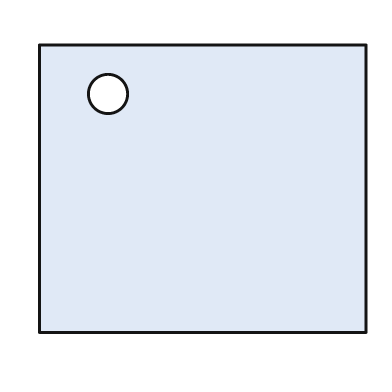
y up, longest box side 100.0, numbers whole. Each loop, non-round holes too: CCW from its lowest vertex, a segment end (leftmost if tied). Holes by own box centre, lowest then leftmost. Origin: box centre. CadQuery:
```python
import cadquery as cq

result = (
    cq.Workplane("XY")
    .moveTo(-50.0, -44.0)
    .lineTo(50.0, -44.0)
    .lineTo(50.0, 44.0)
    .lineTo(-50.0, 44.0)
    .close()
    .moveTo(-29.0, 29.0)
    .circle(6.0)
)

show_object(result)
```